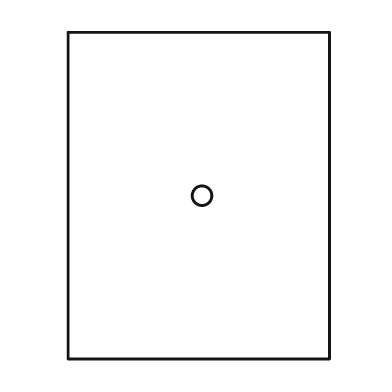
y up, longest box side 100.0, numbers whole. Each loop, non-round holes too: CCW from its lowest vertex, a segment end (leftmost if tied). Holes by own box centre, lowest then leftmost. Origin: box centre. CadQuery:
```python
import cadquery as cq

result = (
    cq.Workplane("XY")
    .moveTo(-40.0, -50.0)
    .lineTo(40.0, -50.0)
    .lineTo(40.0, 50.0)
    .lineTo(-40.0, 50.0)
    .close()
    .moveTo(1.0, 0.0)
    .circle(3.0)
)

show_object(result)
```